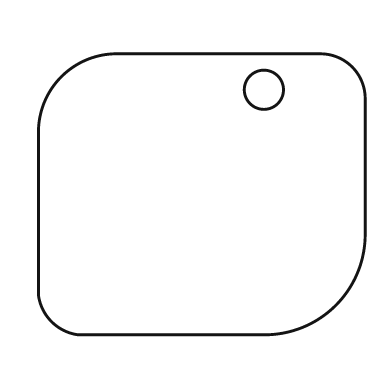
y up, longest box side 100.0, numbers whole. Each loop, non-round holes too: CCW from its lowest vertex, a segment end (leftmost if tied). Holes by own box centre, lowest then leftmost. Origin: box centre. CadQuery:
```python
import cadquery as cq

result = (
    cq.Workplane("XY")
    .moveTo(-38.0, -43.0)
    .lineTo(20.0, -43.0)
    .threePointArc((41.0, -34.0), (50.0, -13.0))
    .lineTo(50.0, 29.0)
    .threePointArc((46.0, 39.0), (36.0, 43.0))
    .lineTo(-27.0, 43.0)
    .threePointArc((-43.0, 36.0), (-50.0, 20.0))
    .lineTo(-50.0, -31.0)
    .threePointArc((-46.0, -39.0), (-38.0, -43.0))
    .close()
    .moveTo(19.0, 32.0)
    .circle(6.0)
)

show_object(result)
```